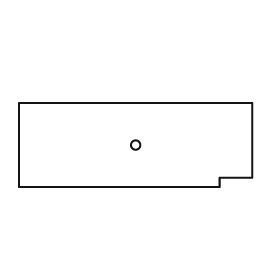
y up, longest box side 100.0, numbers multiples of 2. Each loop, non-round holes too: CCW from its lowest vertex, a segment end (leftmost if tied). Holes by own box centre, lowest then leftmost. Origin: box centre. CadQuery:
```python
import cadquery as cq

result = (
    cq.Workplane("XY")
    .moveTo(-50.0, -18.0)
    .lineTo(36.0, -18.0)
    .lineTo(36.0, -14.0)
    .lineTo(50.0, -14.0)
    .lineTo(50.0, 18.0)
    .lineTo(-50.0, 18.0)
    .close()
    .moveTo(0.0, 0.0)
    .circle(2.0)
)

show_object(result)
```